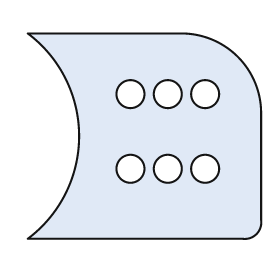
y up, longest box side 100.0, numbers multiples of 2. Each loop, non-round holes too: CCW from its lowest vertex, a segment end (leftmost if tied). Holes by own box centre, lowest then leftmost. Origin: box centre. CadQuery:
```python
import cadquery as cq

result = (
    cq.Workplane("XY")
    .moveTo(-50.0, -44.0)
    .lineTo(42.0, -44.0)
    .threePointArc((48.0, -42.0), (50.0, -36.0))
    .lineTo(50.0, 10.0)
    .threePointArc((40.0, 34.0), (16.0, 44.0))
    .lineTo(-50.0, 44.0)
    .threePointArc((-28.0, 0.0), (-50.0, -44.0))
    .close()
    .moveTo(-6.0, -14.0)
    .circle(6.0)
    .moveTo(10.0, -14.0)
    .circle(6.0)
    .moveTo(26.0, -14.0)
    .circle(6.0)
    .moveTo(-6.0, 18.0)
    .circle(6.0)
    .moveTo(10.0, 18.0)
    .circle(6.0)
    .moveTo(26.0, 18.0)
    .circle(6.0)
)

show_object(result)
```